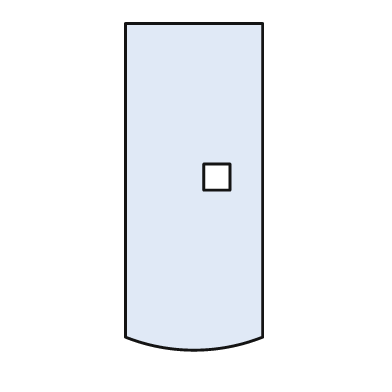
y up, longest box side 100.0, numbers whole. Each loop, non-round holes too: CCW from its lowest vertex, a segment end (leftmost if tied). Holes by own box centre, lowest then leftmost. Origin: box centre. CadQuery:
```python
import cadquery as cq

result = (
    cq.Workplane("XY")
    .moveTo(-21.0, -46.0)
    .threePointArc((0.0, -50.0), (21.0, -46.0))
    .lineTo(21.0, 50.0)
    .lineTo(-21.0, 50.0)
    .close()
    .moveTo(3.0, -1.0)
    .lineTo(11.0, -1.0)
    .lineTo(11.0, 7.0)
    .lineTo(3.0, 7.0)
    .close()
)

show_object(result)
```